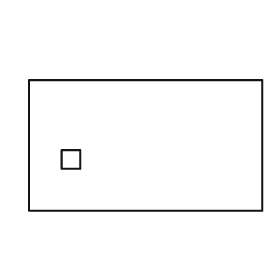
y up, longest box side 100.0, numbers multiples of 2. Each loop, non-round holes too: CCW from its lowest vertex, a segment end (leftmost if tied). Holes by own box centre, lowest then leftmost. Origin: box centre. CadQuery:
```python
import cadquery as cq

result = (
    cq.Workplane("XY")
    .moveTo(-50.0, -28.0)
    .lineTo(50.0, -28.0)
    .lineTo(50.0, 28.0)
    .lineTo(-50.0, 28.0)
    .close()
    .moveTo(-36.0, -10.0)
    .lineTo(-28.0, -10.0)
    .lineTo(-28.0, -2.0)
    .lineTo(-36.0, -2.0)
    .close()
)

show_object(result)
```